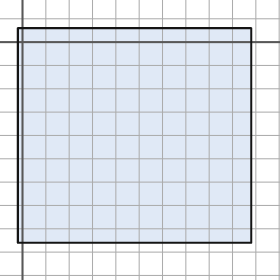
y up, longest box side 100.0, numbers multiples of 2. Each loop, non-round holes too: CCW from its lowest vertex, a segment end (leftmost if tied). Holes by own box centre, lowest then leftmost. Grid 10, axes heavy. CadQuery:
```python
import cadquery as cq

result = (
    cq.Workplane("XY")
    .moveTo(-2.0, -86.0)
    .lineTo(98.0, -86.0)
    .lineTo(98.0, 6.0)
    .lineTo(-2.0, 6.0)
    .close()
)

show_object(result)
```